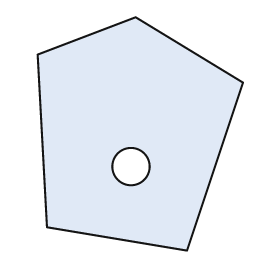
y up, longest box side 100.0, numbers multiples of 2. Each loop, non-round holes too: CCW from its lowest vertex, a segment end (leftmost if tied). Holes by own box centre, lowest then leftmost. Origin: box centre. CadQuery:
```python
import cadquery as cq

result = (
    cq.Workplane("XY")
    .moveTo(20.0, -50.0)
    .lineTo(44.0, 22.0)
    .lineTo(-2.0, 50.0)
    .lineTo(-44.0, 34.0)
    .lineTo(-40.0, -40.0)
    .close()
    .moveTo(-4.0, -14.0)
    .circle(8.0)
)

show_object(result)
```